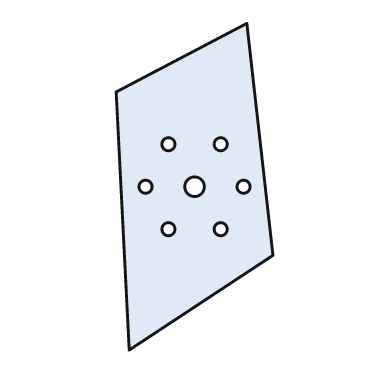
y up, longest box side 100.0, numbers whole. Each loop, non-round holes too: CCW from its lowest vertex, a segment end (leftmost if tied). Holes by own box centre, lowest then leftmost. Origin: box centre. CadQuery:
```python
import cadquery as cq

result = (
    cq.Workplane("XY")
    .moveTo(-20.0, -50.0)
    .lineTo(24.0, -21.0)
    .lineTo(16.0, 50.0)
    .lineTo(-24.0, 29.0)
    .close()
    .moveTo(-8.0, -13.0)
    .circle(2.0)
    .moveTo(8.0, -13.0)
    .circle(2.0)
    .moveTo(-15.0, 0.0)
    .circle(2.0)
    .moveTo(0.0, 0.0)
    .circle(3.0)
    .moveTo(15.0, 0.0)
    .circle(2.0)
    .moveTo(-8.0, 13.0)
    .circle(2.0)
    .moveTo(8.0, 13.0)
    .circle(2.0)
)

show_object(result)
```